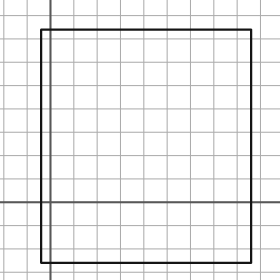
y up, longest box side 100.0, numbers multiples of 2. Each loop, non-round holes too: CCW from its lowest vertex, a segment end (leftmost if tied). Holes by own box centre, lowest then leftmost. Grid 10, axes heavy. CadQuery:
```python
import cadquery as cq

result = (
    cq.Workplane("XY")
    .moveTo(-4.0, -26.0)
    .lineTo(86.0, -26.0)
    .lineTo(86.0, 74.0)
    .lineTo(-4.0, 74.0)
    .close()
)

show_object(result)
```